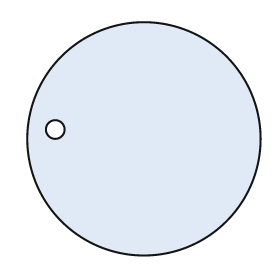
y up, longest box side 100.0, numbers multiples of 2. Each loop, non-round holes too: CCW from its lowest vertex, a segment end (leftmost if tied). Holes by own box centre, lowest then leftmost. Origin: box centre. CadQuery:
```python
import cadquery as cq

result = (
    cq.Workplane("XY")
    .moveTo(0.0, 0.0)
    .circle(50.0)
    .moveTo(-38.0, 4.0)
    .circle(4.0)
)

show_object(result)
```